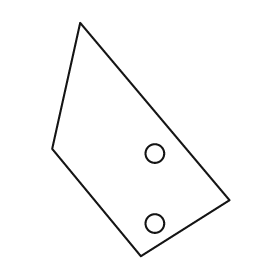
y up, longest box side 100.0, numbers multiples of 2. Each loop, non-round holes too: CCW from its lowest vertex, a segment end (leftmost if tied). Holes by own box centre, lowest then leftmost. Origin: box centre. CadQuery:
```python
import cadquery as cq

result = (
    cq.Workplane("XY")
    .moveTo(0.0, -50.0)
    .lineTo(38.0, -26.0)
    .lineTo(-26.0, 50.0)
    .lineTo(-38.0, -4.0)
    .close()
    .moveTo(6.0, -36.0)
    .circle(4.0)
    .moveTo(6.0, -6.0)
    .circle(4.0)
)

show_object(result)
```